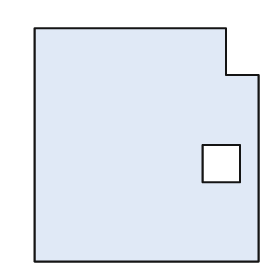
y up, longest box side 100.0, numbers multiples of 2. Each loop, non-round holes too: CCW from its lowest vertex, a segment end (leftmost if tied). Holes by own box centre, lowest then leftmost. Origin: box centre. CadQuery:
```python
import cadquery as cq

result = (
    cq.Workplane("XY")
    .moveTo(-48.0, -50.0)
    .lineTo(48.0, -50.0)
    .lineTo(48.0, 30.0)
    .lineTo(34.0, 30.0)
    .lineTo(34.0, 50.0)
    .lineTo(-48.0, 50.0)
    .close()
    .moveTo(24.0, -16.0)
    .lineTo(40.0, -16.0)
    .lineTo(40.0, 0.0)
    .lineTo(24.0, 0.0)
    .close()
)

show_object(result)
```